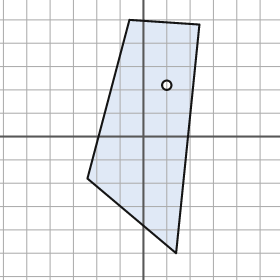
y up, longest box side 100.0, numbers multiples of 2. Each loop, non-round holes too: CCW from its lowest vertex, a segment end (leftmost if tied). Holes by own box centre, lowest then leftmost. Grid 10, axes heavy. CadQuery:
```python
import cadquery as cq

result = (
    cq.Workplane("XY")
    .moveTo(14.0, -50.0)
    .lineTo(24.0, 48.0)
    .lineTo(-6.0, 50.0)
    .lineTo(-24.0, -18.0)
    .close()
    .moveTo(10.0, 22.0)
    .circle(2.0)
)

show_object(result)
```